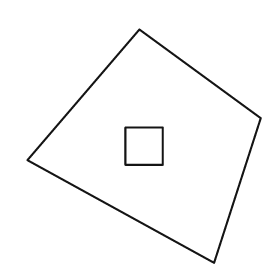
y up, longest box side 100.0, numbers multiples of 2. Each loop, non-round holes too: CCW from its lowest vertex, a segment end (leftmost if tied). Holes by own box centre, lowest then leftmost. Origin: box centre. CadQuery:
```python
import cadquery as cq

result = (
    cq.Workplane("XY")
    .moveTo(30.0, -50.0)
    .lineTo(50.0, 12.0)
    .lineTo(-2.0, 50.0)
    .lineTo(-50.0, -6.0)
    .close()
    .moveTo(-8.0, -8.0)
    .lineTo(8.0, -8.0)
    .lineTo(8.0, 8.0)
    .lineTo(-8.0, 8.0)
    .close()
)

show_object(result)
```